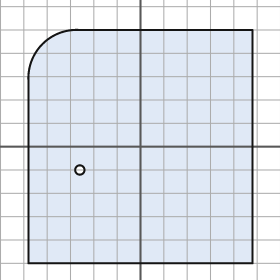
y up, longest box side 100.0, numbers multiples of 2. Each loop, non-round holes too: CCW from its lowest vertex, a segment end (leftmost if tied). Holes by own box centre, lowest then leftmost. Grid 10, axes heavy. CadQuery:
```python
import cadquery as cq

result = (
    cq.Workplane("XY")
    .moveTo(-48.0, -50.0)
    .lineTo(48.0, -50.0)
    .lineTo(48.0, 50.0)
    .lineTo(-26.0, 50.0)
    .threePointArc((-42.0, 44.0), (-48.0, 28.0))
    .close()
    .moveTo(-26.0, -10.0)
    .circle(2.0)
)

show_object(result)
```